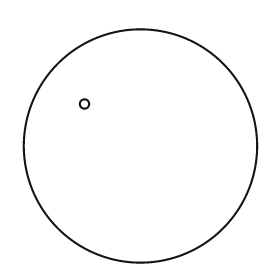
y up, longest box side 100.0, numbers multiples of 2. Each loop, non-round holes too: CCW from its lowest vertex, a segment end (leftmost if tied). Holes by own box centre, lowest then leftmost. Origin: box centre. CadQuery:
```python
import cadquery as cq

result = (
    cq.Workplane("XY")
    .moveTo(0.0, 0.0)
    .circle(50.0)
    .moveTo(-24.0, 18.0)
    .circle(2.0)
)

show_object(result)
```